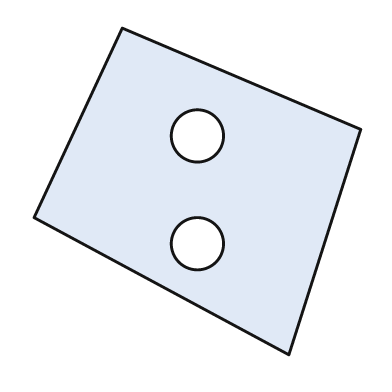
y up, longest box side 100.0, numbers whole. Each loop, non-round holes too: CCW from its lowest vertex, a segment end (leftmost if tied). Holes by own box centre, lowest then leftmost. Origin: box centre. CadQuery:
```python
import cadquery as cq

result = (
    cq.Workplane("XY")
    .moveTo(28.0, -50.0)
    .lineTo(50.0, 19.0)
    .lineTo(-23.0, 50.0)
    .lineTo(-50.0, -8.0)
    .close()
    .moveTo(0.0, -16.0)
    .circle(8.0)
    .moveTo(0.0, 17.0)
    .circle(8.0)
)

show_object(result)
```